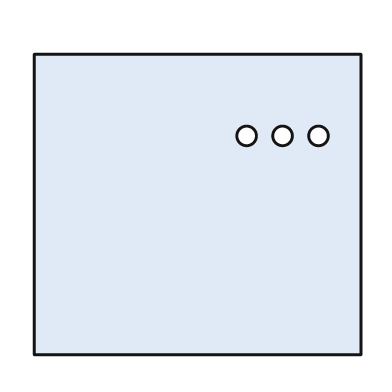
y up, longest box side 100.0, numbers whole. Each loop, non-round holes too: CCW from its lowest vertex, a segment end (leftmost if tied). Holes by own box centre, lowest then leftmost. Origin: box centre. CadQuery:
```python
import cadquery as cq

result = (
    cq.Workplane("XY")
    .moveTo(-50.0, -46.0)
    .lineTo(50.0, -46.0)
    .lineTo(50.0, 46.0)
    .lineTo(-50.0, 46.0)
    .close()
    .moveTo(15.0, 21.0)
    .circle(3.0)
    .moveTo(26.0, 21.0)
    .circle(3.0)
    .moveTo(37.0, 21.0)
    .circle(3.0)
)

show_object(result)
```